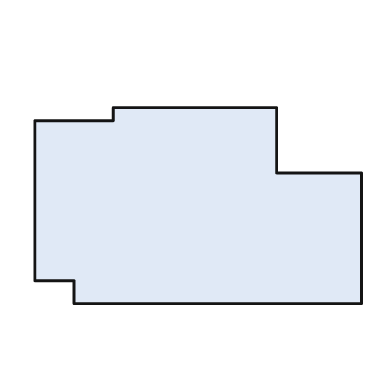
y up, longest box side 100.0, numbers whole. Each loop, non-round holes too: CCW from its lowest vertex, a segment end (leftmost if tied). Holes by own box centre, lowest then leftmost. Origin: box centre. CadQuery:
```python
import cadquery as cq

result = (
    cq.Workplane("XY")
    .moveTo(-38.0, -30.0)
    .lineTo(50.0, -30.0)
    .lineTo(50.0, 10.0)
    .lineTo(24.0, 10.0)
    .lineTo(24.0, 30.0)
    .lineTo(-26.0, 30.0)
    .lineTo(-26.0, 26.0)
    .lineTo(-50.0, 26.0)
    .lineTo(-50.0, -23.0)
    .lineTo(-38.0, -23.0)
    .close()
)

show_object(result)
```